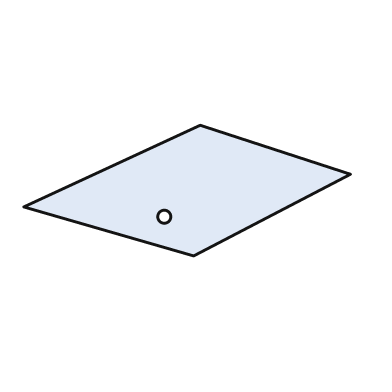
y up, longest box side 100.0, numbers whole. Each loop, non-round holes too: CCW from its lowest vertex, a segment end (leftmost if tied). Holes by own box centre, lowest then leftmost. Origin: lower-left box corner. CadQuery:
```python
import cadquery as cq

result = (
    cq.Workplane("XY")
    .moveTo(52.0, 0.0)
    .lineTo(100.0, 25.0)
    .lineTo(54.0, 40.0)
    .lineTo(0.0, 15.0)
    .close()
    .moveTo(43.0, 12.0)
    .circle(2.0)
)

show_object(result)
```